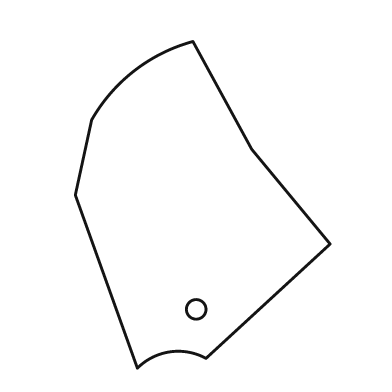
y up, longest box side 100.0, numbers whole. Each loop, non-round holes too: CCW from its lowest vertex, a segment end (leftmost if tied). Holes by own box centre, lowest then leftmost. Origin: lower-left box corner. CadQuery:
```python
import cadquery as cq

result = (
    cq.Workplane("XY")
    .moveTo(19.0, 0.0)
    .threePointArc((29.0, 5.0), (40.0, 3.0))
    .lineTo(78.0, 38.0)
    .lineTo(54.0, 67.0)
    .lineTo(36.0, 100.0)
    .threePointArc((18.0, 91.0), (5.0, 76.0))
    .lineTo(0.0, 53.0)
    .close()
    .moveTo(37.0, 18.0)
    .circle(3.0)
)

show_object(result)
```